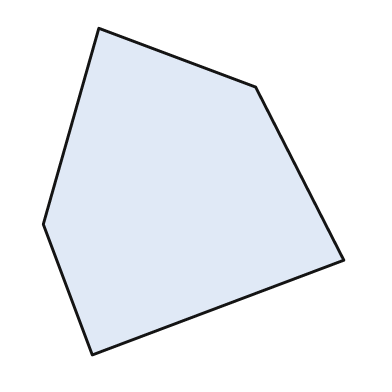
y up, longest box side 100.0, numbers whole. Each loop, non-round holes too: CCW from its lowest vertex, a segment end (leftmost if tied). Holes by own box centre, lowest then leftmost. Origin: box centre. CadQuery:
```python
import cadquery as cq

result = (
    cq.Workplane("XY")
    .moveTo(-31.0, -50.0)
    .lineTo(46.0, -21.0)
    .lineTo(19.0, 32.0)
    .lineTo(-29.0, 50.0)
    .lineTo(-46.0, -10.0)
    .close()
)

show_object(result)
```